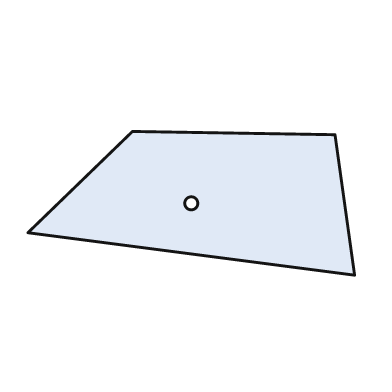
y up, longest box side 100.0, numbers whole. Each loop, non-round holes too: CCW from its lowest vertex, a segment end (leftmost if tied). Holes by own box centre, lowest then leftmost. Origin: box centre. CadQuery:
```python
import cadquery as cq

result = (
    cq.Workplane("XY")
    .moveTo(50.0, -22.0)
    .lineTo(44.0, 21.0)
    .lineTo(-18.0, 22.0)
    .lineTo(-50.0, -9.0)
    .close()
    .moveTo(0.0, 0.0)
    .circle(2.0)
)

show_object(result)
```